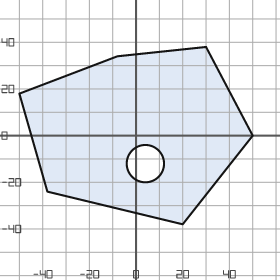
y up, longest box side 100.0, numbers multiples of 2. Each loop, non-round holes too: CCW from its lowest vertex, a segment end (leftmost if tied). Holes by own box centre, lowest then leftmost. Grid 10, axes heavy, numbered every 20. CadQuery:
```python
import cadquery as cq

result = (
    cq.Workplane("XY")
    .moveTo(20.0, -38.0)
    .lineTo(50.0, 0.0)
    .lineTo(30.0, 38.0)
    .lineTo(-8.0, 34.0)
    .lineTo(-50.0, 18.0)
    .lineTo(-38.0, -24.0)
    .close()
    .moveTo(4.0, -12.0)
    .circle(8.0)
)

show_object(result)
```